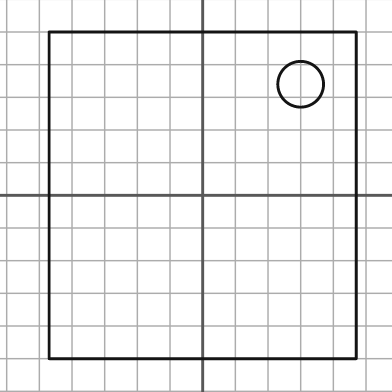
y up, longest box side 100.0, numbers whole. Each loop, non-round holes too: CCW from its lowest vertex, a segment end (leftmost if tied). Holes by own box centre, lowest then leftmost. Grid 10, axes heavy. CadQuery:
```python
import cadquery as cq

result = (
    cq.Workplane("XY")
    .moveTo(-47.0, -50.0)
    .lineTo(47.0, -50.0)
    .lineTo(47.0, 50.0)
    .lineTo(-47.0, 50.0)
    .close()
    .moveTo(30.0, 34.0)
    .circle(7.0)
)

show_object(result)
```